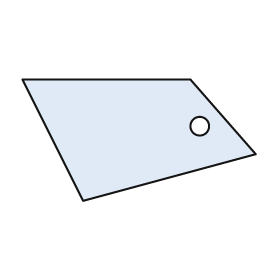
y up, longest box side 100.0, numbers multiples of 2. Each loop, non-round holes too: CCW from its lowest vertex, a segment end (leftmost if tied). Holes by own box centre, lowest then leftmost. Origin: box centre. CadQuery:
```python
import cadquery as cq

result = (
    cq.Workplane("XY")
    .moveTo(-24.0, -26.0)
    .lineTo(50.0, -6.0)
    .lineTo(22.0, 26.0)
    .lineTo(-50.0, 26.0)
    .close()
    .moveTo(26.0, 6.0)
    .circle(4.0)
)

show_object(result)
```